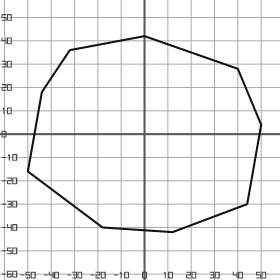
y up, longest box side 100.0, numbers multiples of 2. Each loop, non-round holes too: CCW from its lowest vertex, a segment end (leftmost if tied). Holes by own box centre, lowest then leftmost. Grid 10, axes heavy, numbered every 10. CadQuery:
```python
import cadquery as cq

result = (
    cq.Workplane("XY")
    .moveTo(12.0, -42.0)
    .lineTo(44.0, -30.0)
    .lineTo(50.0, 4.0)
    .lineTo(40.0, 28.0)
    .lineTo(0.0, 42.0)
    .lineTo(-32.0, 36.0)
    .lineTo(-44.0, 18.0)
    .lineTo(-50.0, -16.0)
    .lineTo(-18.0, -40.0)
    .close()
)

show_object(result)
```